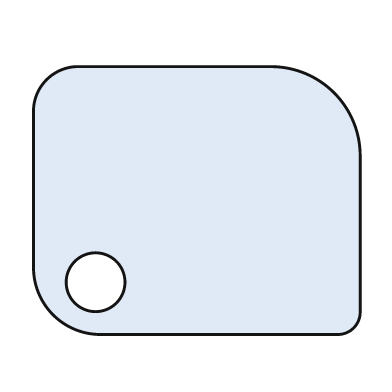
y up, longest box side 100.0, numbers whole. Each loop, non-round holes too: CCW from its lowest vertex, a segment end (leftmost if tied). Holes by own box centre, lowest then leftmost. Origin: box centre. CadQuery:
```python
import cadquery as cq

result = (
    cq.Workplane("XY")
    .moveTo(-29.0, -41.0)
    .lineTo(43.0, -41.0)
    .threePointArc((48.0, -39.0), (50.0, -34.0))
    .lineTo(50.0, 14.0)
    .threePointArc((42.0, 33.0), (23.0, 41.0))
    .lineTo(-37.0, 41.0)
    .threePointArc((-46.0, 37.0), (-50.0, 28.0))
    .lineTo(-50.0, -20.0)
    .threePointArc((-44.0, -35.0), (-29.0, -41.0))
    .close()
    .moveTo(-31.0, -25.0)
    .circle(9.0)
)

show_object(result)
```